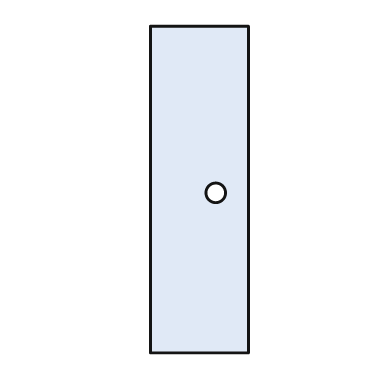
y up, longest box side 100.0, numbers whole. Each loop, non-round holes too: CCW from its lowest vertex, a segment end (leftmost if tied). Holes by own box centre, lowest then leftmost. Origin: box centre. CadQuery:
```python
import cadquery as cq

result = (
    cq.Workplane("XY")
    .moveTo(-15.0, -50.0)
    .lineTo(15.0, -50.0)
    .lineTo(15.0, 50.0)
    .lineTo(-15.0, 50.0)
    .close()
    .moveTo(5.0, -1.0)
    .circle(3.0)
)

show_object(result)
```